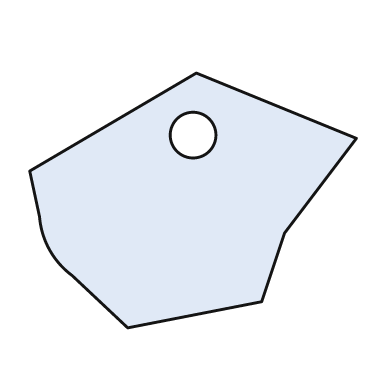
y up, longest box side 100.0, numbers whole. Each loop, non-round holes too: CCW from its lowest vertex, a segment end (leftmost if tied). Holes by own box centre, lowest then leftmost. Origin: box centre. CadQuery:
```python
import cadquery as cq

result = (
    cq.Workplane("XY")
    .moveTo(-20.0, -39.0)
    .lineTo(21.0, -31.0)
    .lineTo(28.0, -10.0)
    .lineTo(50.0, 19.0)
    .lineTo(1.0, 39.0)
    .lineTo(-50.0, 9.0)
    .lineTo(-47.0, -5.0)
    .threePointArc((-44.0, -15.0), (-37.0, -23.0))
    .close()
    .moveTo(0.0, 20.0)
    .circle(7.0)
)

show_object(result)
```